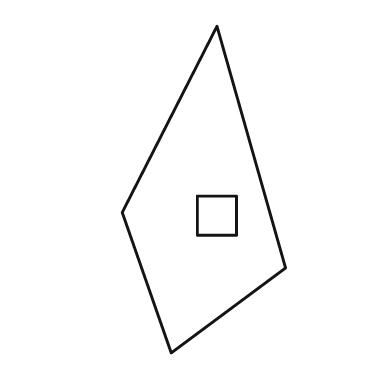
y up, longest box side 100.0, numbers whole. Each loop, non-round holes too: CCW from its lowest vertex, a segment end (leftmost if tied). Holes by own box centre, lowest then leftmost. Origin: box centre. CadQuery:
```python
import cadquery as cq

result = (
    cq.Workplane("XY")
    .moveTo(-10.0, -50.0)
    .lineTo(25.0, -24.0)
    .lineTo(4.0, 50.0)
    .lineTo(-25.0, -7.0)
    .close()
    .moveTo(-2.0, -14.0)
    .lineTo(10.0, -14.0)
    .lineTo(10.0, -2.0)
    .lineTo(-2.0, -2.0)
    .close()
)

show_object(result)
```